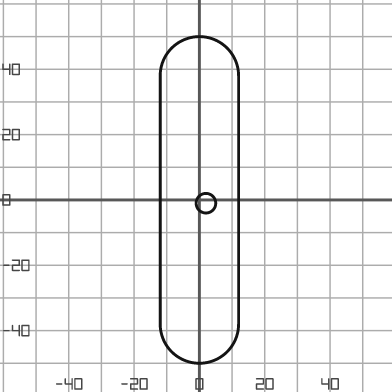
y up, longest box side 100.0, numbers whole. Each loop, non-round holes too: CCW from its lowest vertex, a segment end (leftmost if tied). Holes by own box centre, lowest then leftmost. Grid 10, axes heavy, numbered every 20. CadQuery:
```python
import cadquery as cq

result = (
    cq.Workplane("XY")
    .moveTo(-12.0, -38.0)
    .threePointArc((0.0, -50.0), (12.0, -38.0))
    .lineTo(12.0, 38.0)
    .threePointArc((0.0, 50.0), (-12.0, 38.0))
    .close()
    .moveTo(2.0, -1.0)
    .circle(3.0)
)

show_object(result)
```